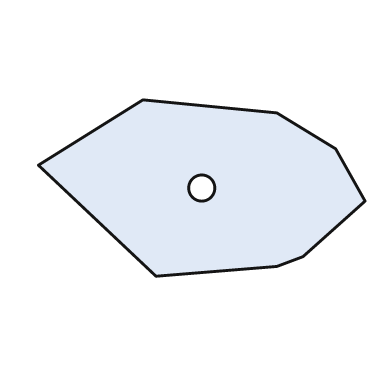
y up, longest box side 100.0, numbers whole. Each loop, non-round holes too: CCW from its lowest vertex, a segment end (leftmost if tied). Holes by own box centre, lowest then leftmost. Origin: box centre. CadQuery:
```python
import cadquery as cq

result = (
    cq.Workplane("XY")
    .moveTo(-14.0, -27.0)
    .lineTo(23.0, -24.0)
    .lineTo(31.0, -21.0)
    .lineTo(50.0, -4.0)
    .lineTo(41.0, 12.0)
    .lineTo(23.0, 23.0)
    .lineTo(-18.0, 27.0)
    .lineTo(-50.0, 7.0)
    .close()
    .moveTo(0.0, 0.0)
    .circle(4.0)
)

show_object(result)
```